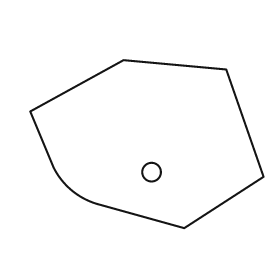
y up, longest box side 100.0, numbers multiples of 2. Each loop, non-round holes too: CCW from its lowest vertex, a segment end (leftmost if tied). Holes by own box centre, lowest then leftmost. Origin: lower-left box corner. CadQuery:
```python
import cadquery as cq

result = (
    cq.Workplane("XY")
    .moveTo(66.0, 0.0)
    .lineTo(100.0, 22.0)
    .lineTo(84.0, 68.0)
    .lineTo(40.0, 72.0)
    .lineTo(0.0, 50.0)
    .lineTo(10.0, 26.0)
    .threePointArc((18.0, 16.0), (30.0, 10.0))
    .close()
    .moveTo(52.0, 24.0)
    .circle(4.0)
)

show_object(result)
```